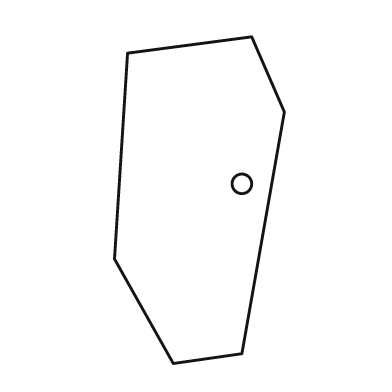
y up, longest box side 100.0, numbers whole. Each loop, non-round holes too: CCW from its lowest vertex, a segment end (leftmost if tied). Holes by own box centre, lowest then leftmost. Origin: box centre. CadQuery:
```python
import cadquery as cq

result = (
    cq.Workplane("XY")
    .moveTo(-8.0, -50.0)
    .lineTo(13.0, -47.0)
    .lineTo(26.0, 27.0)
    .lineTo(16.0, 50.0)
    .lineTo(-22.0, 45.0)
    .lineTo(-26.0, -18.0)
    .close()
    .moveTo(13.0, 5.0)
    .circle(3.0)
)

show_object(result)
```